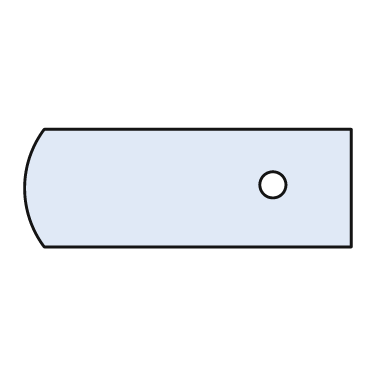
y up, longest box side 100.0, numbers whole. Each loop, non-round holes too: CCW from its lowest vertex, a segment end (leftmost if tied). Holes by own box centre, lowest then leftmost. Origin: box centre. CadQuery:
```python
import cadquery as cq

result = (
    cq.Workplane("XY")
    .moveTo(-44.0, -18.0)
    .lineTo(50.0, -18.0)
    .lineTo(50.0, 18.0)
    .lineTo(-44.0, 18.0)
    .threePointArc((-50.0, 0.0), (-44.0, -18.0))
    .close()
    .moveTo(26.0, 1.0)
    .circle(4.0)
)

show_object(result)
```